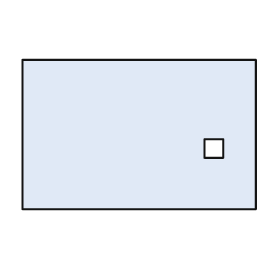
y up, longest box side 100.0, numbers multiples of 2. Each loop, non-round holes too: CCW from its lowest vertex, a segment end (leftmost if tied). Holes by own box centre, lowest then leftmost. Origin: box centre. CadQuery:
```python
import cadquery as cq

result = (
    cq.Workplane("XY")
    .moveTo(-50.0, -32.0)
    .lineTo(50.0, -32.0)
    .lineTo(50.0, 32.0)
    .lineTo(-50.0, 32.0)
    .close()
    .moveTo(28.0, -10.0)
    .lineTo(36.0, -10.0)
    .lineTo(36.0, -2.0)
    .lineTo(28.0, -2.0)
    .close()
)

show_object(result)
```